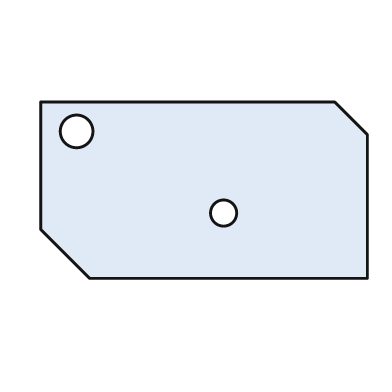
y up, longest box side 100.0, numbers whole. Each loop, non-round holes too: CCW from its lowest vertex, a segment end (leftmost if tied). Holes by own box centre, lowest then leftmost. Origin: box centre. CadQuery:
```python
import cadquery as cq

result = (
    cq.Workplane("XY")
    .moveTo(-35.0, -27.0)
    .lineTo(50.0, -27.0)
    .lineTo(50.0, 17.0)
    .lineTo(40.0, 27.0)
    .lineTo(-50.0, 27.0)
    .lineTo(-50.0, -12.0)
    .close()
    .moveTo(6.0, -7.0)
    .circle(4.0)
    .moveTo(-39.0, 18.0)
    .circle(5.0)
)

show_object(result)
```